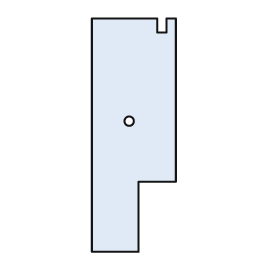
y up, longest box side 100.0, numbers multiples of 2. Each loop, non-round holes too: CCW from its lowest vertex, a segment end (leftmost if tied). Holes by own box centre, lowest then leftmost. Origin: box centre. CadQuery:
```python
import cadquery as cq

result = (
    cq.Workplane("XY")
    .moveTo(-18.0, -50.0)
    .lineTo(2.0, -50.0)
    .lineTo(2.0, -20.0)
    .lineTo(18.0, -20.0)
    .lineTo(18.0, 50.0)
    .lineTo(14.0, 50.0)
    .lineTo(14.0, 44.0)
    .lineTo(10.0, 44.0)
    .lineTo(10.0, 50.0)
    .lineTo(-18.0, 50.0)
    .close()
    .moveTo(-2.0, 6.0)
    .circle(2.0)
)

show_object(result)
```